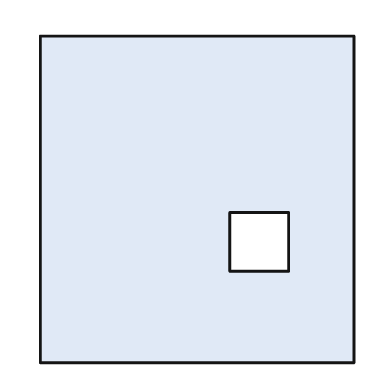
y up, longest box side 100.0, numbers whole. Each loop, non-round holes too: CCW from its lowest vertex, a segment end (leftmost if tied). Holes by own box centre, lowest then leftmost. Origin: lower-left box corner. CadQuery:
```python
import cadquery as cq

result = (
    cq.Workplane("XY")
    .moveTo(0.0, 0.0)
    .lineTo(96.0, 0.0)
    .lineTo(96.0, 100.0)
    .lineTo(0.0, 100.0)
    .close()
    .moveTo(58.0, 28.0)
    .lineTo(76.0, 28.0)
    .lineTo(76.0, 46.0)
    .lineTo(58.0, 46.0)
    .close()
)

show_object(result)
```